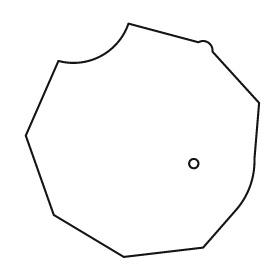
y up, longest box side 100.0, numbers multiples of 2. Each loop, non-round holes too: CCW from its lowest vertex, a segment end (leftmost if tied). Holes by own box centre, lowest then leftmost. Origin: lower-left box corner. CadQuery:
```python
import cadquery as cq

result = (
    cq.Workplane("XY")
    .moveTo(42.0, 0.0)
    .lineTo(76.0, 4.0)
    .lineTo(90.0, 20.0)
    .threePointArc((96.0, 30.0), (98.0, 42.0))
    .lineTo(100.0, 66.0)
    .lineTo(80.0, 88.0)
    .threePointArc((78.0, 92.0), (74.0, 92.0))
    .lineTo(44.0, 100.0)
    .threePointArc((32.0, 86.0), (14.0, 84.0))
    .lineTo(0.0, 52.0)
    .lineTo(12.0, 18.0)
    .close()
    .moveTo(72.0, 40.0)
    .circle(2.0)
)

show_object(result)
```